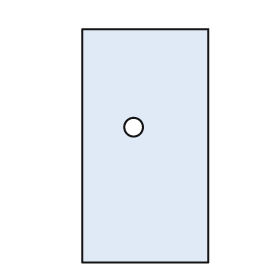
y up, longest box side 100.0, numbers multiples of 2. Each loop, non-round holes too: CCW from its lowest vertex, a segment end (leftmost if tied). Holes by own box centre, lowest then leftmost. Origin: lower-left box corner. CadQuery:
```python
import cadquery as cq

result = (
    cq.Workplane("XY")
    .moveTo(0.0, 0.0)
    .lineTo(54.0, 0.0)
    .lineTo(54.0, 100.0)
    .lineTo(0.0, 100.0)
    .close()
    .moveTo(22.0, 58.0)
    .circle(4.0)
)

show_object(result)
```